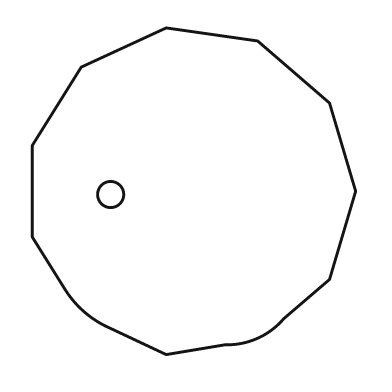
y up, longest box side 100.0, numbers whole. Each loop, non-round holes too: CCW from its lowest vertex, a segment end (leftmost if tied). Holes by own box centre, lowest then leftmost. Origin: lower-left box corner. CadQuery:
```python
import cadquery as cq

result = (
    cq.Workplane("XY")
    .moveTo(41.0, 0.0)
    .lineTo(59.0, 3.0)
    .threePointArc((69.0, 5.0), (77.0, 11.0))
    .lineTo(91.0, 23.0)
    .lineTo(99.0, 50.0)
    .lineTo(91.0, 77.0)
    .lineTo(69.0, 96.0)
    .lineTo(41.0, 100.0)
    .lineTo(15.0, 88.0)
    .lineTo(0.0, 64.0)
    .lineTo(0.0, 36.0)
    .lineTo(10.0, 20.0)
    .threePointArc((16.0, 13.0), (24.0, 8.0))
    .close()
    .moveTo(24.0, 49.0)
    .circle(4.0)
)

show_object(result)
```